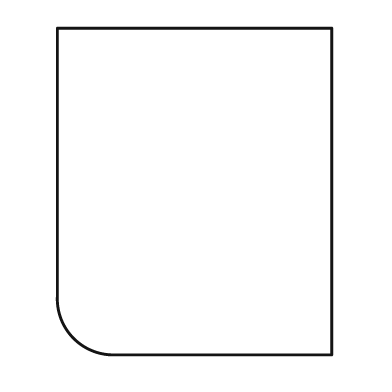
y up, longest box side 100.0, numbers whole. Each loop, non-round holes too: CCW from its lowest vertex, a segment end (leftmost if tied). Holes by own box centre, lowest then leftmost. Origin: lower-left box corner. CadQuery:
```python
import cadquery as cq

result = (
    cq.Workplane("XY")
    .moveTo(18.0, 0.0)
    .lineTo(84.0, 0.0)
    .lineTo(84.0, 100.0)
    .lineTo(0.0, 100.0)
    .lineTo(0.0, 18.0)
    .threePointArc((5.0, 5.0), (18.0, 0.0))
    .close()
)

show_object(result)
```